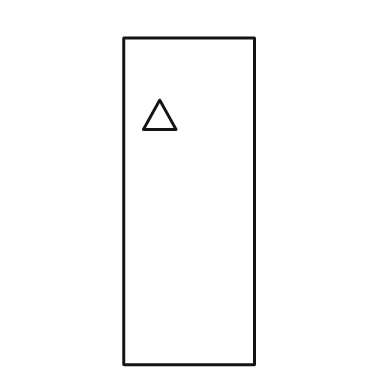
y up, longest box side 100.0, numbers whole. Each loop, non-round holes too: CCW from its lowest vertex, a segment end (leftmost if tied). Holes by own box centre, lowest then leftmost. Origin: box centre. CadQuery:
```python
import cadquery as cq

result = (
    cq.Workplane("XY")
    .moveTo(-20.0, -50.0)
    .lineTo(20.0, -50.0)
    .lineTo(20.0, 50.0)
    .lineTo(-20.0, 50.0)
    .close()
    .moveTo(-14.0, 22.0)
    .lineTo(-4.0, 22.0)
    .lineTo(-9.0, 31.0)
    .close()
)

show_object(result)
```